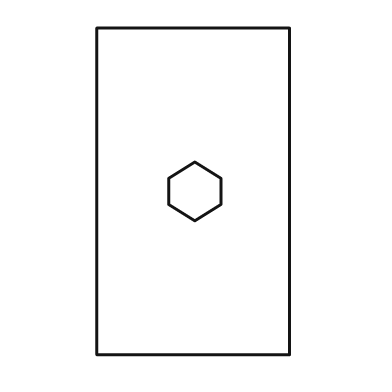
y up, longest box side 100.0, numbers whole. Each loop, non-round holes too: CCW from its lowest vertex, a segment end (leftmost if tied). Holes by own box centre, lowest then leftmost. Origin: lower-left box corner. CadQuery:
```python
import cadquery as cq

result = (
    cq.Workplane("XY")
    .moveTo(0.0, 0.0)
    .lineTo(59.0, 0.0)
    .lineTo(59.0, 100.0)
    .lineTo(0.0, 100.0)
    .close()
    .moveTo(30.0, 41.0)
    .lineTo(38.0, 46.0)
    .lineTo(38.0, 54.0)
    .lineTo(30.0, 59.0)
    .lineTo(22.0, 54.0)
    .lineTo(22.0, 46.0)
    .close()
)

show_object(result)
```